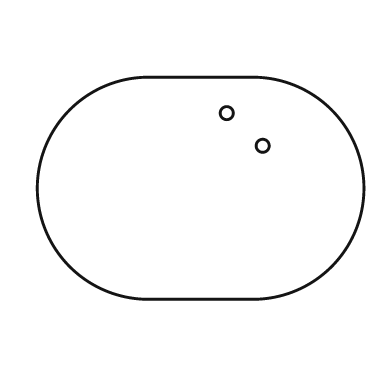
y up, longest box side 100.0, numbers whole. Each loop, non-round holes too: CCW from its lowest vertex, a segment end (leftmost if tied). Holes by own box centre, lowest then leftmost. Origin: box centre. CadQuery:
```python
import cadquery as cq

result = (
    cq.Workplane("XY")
    .moveTo(-16.0, -34.0)
    .lineTo(16.0, -34.0)
    .threePointArc((50.0, 0.0), (16.0, 34.0))
    .lineTo(-16.0, 34.0)
    .threePointArc((-50.0, 0.0), (-16.0, -34.0))
    .close()
    .moveTo(19.0, 13.0)
    .circle(2.0)
    .moveTo(8.0, 23.0)
    .circle(2.0)
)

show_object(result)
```